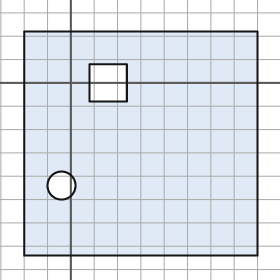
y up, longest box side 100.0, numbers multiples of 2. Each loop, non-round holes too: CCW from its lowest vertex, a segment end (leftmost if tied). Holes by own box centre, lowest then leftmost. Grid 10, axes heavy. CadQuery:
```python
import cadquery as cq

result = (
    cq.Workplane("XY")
    .moveTo(-20.0, -74.0)
    .lineTo(80.0, -74.0)
    .lineTo(80.0, 22.0)
    .lineTo(-20.0, 22.0)
    .close()
    .moveTo(-4.0, -44.0)
    .circle(6.0)
    .moveTo(8.0, -8.0)
    .lineTo(24.0, -8.0)
    .lineTo(24.0, 8.0)
    .lineTo(8.0, 8.0)
    .close()
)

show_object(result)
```